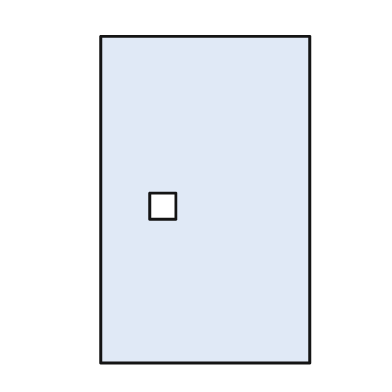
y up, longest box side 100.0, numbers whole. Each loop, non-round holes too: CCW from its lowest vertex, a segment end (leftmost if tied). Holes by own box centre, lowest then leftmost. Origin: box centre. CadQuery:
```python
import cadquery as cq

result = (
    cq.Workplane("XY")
    .moveTo(-32.0, -50.0)
    .lineTo(32.0, -50.0)
    .lineTo(32.0, 50.0)
    .lineTo(-32.0, 50.0)
    .close()
    .moveTo(-17.0, -6.0)
    .lineTo(-9.0, -6.0)
    .lineTo(-9.0, 2.0)
    .lineTo(-17.0, 2.0)
    .close()
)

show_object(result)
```